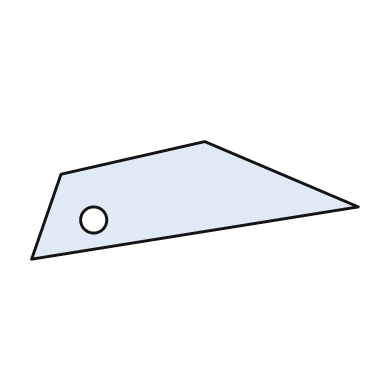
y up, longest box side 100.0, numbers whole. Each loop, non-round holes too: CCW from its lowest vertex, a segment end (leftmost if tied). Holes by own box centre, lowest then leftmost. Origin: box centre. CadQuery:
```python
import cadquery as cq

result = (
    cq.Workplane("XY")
    .moveTo(-50.0, -18.0)
    .lineTo(50.0, -2.0)
    .lineTo(3.0, 18.0)
    .lineTo(-41.0, 8.0)
    .close()
    .moveTo(-31.0, -6.0)
    .circle(4.0)
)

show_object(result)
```